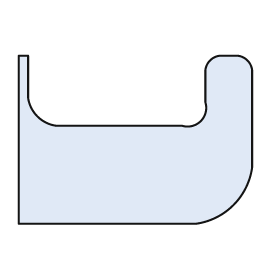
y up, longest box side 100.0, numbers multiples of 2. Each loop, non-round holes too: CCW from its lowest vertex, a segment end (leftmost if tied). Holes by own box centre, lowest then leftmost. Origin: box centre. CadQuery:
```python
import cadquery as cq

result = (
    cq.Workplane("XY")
    .moveTo(-50.0, -36.0)
    .lineTo(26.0, -36.0)
    .threePointArc((42.0, -28.0), (50.0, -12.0))
    .lineTo(50.0, 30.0)
    .threePointArc((48.0, 34.0), (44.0, 36.0))
    .lineTo(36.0, 36.0)
    .threePointArc((32.0, 34.0), (30.0, 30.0))
    .lineTo(30.0, 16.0)
    .threePointArc((28.0, 8.0), (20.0, 6.0))
    .lineTo(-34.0, 6.0)
    .threePointArc((-42.0, 10.0), (-46.0, 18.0))
    .lineTo(-46.0, 36.0)
    .lineTo(-50.0, 36.0)
    .close()
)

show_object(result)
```